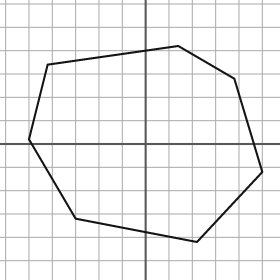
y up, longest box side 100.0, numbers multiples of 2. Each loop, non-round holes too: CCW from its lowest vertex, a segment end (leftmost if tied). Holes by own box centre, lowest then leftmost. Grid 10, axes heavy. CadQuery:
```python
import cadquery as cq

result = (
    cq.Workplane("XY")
    .moveTo(22.0, -42.0)
    .lineTo(50.0, -12.0)
    .lineTo(38.0, 28.0)
    .lineTo(14.0, 42.0)
    .lineTo(-42.0, 34.0)
    .lineTo(-50.0, 2.0)
    .lineTo(-30.0, -32.0)
    .close()
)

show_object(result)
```